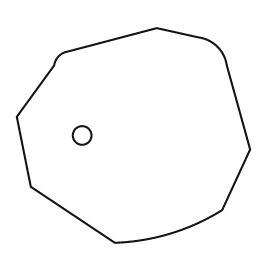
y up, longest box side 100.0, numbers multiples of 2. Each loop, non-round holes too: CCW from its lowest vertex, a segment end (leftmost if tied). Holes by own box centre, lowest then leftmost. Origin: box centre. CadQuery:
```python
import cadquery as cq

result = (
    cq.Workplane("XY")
    .moveTo(-8.0, -46.0)
    .threePointArc((16.0, -42.0), (38.0, -32.0))
    .lineTo(50.0, -6.0)
    .lineTo(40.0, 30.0)
    .threePointArc((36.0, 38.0), (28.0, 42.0))
    .lineTo(10.0, 46.0)
    .lineTo(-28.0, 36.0)
    .threePointArc((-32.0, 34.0), (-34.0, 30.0))
    .lineTo(-50.0, 8.0)
    .lineTo(-44.0, -22.0)
    .close()
    .moveTo(-22.0, 0.0)
    .circle(4.0)
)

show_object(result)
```